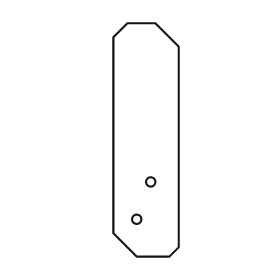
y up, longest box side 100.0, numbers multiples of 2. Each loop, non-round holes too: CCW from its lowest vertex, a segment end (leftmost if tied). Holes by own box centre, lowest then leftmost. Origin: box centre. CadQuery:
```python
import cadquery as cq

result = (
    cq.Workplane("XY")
    .moveTo(-4.0, -50.0)
    .lineTo(10.0, -50.0)
    .lineTo(14.0, -46.0)
    .lineTo(14.0, 40.0)
    .lineTo(4.0, 50.0)
    .lineTo(-8.0, 50.0)
    .lineTo(-14.0, 44.0)
    .lineTo(-14.0, -40.0)
    .close()
    .moveTo(-4.0, -34.0)
    .circle(2.0)
    .moveTo(2.0, -18.0)
    .circle(2.0)
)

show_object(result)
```